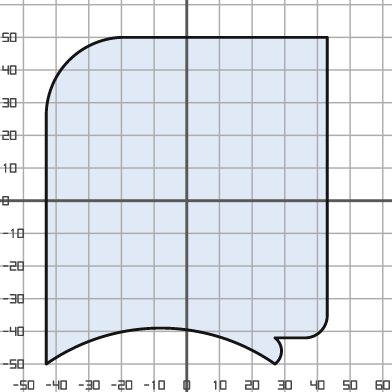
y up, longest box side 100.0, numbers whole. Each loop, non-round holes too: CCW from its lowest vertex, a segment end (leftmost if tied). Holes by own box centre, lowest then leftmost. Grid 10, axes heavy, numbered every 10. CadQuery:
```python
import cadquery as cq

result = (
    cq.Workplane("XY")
    .moveTo(-43.0, -50.0)
    .threePointArc((-8.0, -39.0), (27.0, -50.0))
    .threePointArc((29.0, -46.0), (27.0, -42.0))
    .lineTo(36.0, -42.0)
    .threePointArc((41.0, -40.0), (43.0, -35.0))
    .lineTo(43.0, 50.0)
    .lineTo(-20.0, 50.0)
    .threePointArc((-36.0, 43.0), (-43.0, 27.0))
    .close()
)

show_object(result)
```